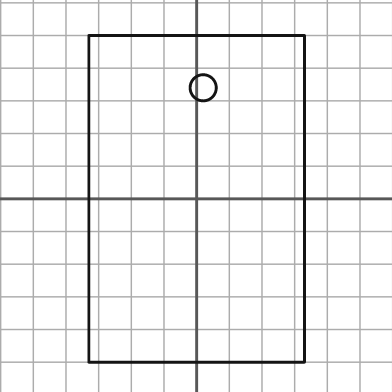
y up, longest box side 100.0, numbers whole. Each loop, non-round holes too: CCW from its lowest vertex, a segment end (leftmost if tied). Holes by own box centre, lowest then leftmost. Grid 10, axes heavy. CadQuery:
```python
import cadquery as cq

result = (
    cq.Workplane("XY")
    .moveTo(-33.0, -50.0)
    .lineTo(33.0, -50.0)
    .lineTo(33.0, 50.0)
    .lineTo(-33.0, 50.0)
    .close()
    .moveTo(2.0, 34.0)
    .circle(4.0)
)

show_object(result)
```